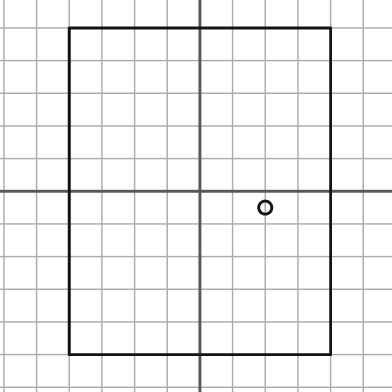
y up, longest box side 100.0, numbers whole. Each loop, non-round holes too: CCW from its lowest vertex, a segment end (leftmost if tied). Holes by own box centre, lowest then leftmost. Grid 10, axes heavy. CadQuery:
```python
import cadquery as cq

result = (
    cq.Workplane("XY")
    .moveTo(-40.0, -50.0)
    .lineTo(40.0, -50.0)
    .lineTo(40.0, 50.0)
    .lineTo(-40.0, 50.0)
    .close()
    .moveTo(20.0, -5.0)
    .circle(2.0)
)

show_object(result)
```